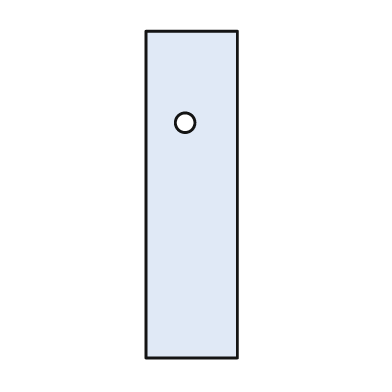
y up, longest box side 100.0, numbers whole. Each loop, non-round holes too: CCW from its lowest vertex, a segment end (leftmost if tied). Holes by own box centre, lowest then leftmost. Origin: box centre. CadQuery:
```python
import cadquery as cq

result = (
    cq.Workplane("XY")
    .moveTo(-14.0, -50.0)
    .lineTo(14.0, -50.0)
    .lineTo(14.0, 50.0)
    .lineTo(-14.0, 50.0)
    .close()
    .moveTo(-2.0, 22.0)
    .circle(3.0)
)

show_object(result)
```